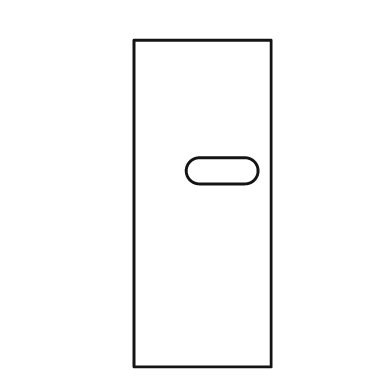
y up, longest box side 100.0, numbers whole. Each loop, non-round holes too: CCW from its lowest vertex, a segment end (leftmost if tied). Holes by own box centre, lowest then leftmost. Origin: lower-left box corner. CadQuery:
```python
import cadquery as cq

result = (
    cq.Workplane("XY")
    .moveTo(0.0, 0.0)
    .lineTo(42.0, 0.0)
    .lineTo(42.0, 100.0)
    .lineTo(0.0, 100.0)
    .close()
    .moveTo(20.0, 56.0)
    .lineTo(34.0, 56.0)
    .threePointArc((38.0, 60.0), (34.0, 64.0))
    .lineTo(20.0, 64.0)
    .threePointArc((16.0, 60.0), (20.0, 56.0))
    .close()
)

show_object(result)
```